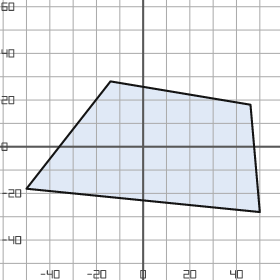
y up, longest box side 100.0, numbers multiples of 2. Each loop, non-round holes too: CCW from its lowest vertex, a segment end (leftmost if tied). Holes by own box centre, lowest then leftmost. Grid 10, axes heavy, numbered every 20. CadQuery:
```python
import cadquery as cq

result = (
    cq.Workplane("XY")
    .moveTo(50.0, -28.0)
    .lineTo(46.0, 18.0)
    .lineTo(-14.0, 28.0)
    .lineTo(-50.0, -18.0)
    .close()
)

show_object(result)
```